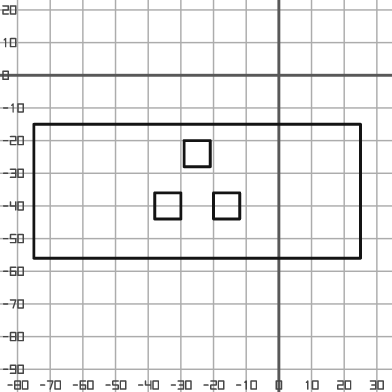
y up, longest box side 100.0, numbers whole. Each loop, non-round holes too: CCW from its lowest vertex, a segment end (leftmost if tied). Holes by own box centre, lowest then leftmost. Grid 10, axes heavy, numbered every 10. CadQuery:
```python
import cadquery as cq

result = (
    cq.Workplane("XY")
    .moveTo(-75.0, -56.0)
    .lineTo(25.0, -56.0)
    .lineTo(25.0, -15.0)
    .lineTo(-75.0, -15.0)
    .close()
    .moveTo(-38.0, -44.0)
    .lineTo(-30.0, -44.0)
    .lineTo(-30.0, -36.0)
    .lineTo(-38.0, -36.0)
    .close()
    .moveTo(-20.0, -44.0)
    .lineTo(-12.0, -44.0)
    .lineTo(-12.0, -36.0)
    .lineTo(-20.0, -36.0)
    .close()
    .moveTo(-29.0, -28.0)
    .lineTo(-21.0, -28.0)
    .lineTo(-21.0, -20.0)
    .lineTo(-29.0, -20.0)
    .close()
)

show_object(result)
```